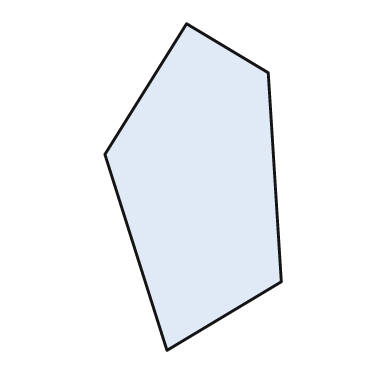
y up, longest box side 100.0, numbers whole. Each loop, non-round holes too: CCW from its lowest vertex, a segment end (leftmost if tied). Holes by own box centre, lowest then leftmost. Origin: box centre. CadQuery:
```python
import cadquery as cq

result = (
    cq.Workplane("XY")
    .moveTo(-8.0, -50.0)
    .lineTo(27.0, -29.0)
    .lineTo(23.0, 35.0)
    .lineTo(-2.0, 50.0)
    .lineTo(-27.0, 10.0)
    .close()
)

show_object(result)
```